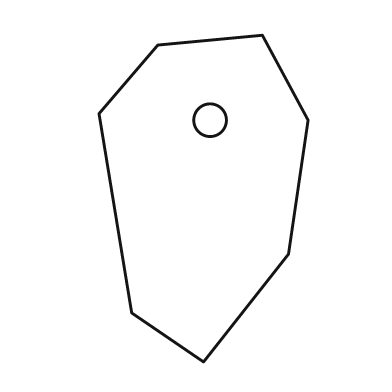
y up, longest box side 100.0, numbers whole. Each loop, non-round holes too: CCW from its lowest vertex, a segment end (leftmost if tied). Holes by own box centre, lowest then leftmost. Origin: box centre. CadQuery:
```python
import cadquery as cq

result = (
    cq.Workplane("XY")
    .moveTo(0.0, -50.0)
    .lineTo(26.0, -17.0)
    .lineTo(32.0, 24.0)
    .lineTo(18.0, 50.0)
    .lineTo(-14.0, 47.0)
    .lineTo(-32.0, 26.0)
    .lineTo(-22.0, -35.0)
    .close()
    .moveTo(2.0, 24.0)
    .circle(5.0)
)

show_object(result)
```